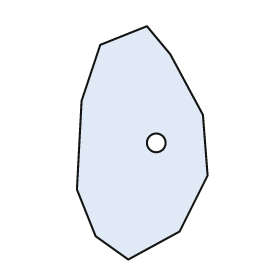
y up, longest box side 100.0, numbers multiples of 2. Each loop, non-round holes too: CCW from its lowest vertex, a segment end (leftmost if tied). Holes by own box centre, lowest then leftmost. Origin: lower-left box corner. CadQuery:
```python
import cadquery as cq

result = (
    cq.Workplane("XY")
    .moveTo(22.0, 0.0)
    .lineTo(44.0, 12.0)
    .lineTo(56.0, 36.0)
    .lineTo(54.0, 62.0)
    .lineTo(40.0, 88.0)
    .lineTo(30.0, 100.0)
    .lineTo(10.0, 92.0)
    .lineTo(2.0, 68.0)
    .lineTo(0.0, 30.0)
    .lineTo(8.0, 10.0)
    .close()
    .moveTo(34.0, 50.0)
    .circle(4.0)
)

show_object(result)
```